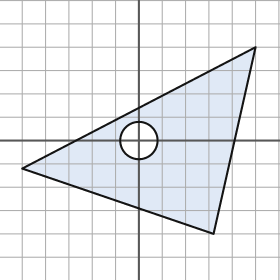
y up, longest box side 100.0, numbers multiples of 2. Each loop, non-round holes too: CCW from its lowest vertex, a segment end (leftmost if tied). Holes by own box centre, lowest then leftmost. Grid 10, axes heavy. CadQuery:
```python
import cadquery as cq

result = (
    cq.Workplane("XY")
    .moveTo(32.0, -40.0)
    .lineTo(50.0, 40.0)
    .lineTo(-50.0, -12.0)
    .close()
    .moveTo(0.0, 0.0)
    .circle(8.0)
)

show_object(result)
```